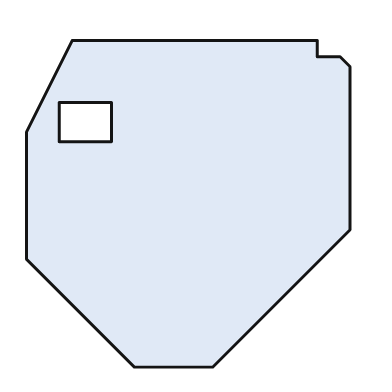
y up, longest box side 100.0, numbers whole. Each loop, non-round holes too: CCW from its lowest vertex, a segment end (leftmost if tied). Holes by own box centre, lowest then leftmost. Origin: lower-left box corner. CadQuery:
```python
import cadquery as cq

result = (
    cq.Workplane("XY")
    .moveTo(33.0, 0.0)
    .lineTo(57.0, 0.0)
    .lineTo(99.0, 42.0)
    .lineTo(99.0, 92.0)
    .lineTo(96.0, 95.0)
    .lineTo(89.0, 95.0)
    .lineTo(89.0, 100.0)
    .lineTo(14.0, 100.0)
    .lineTo(0.0, 72.0)
    .lineTo(0.0, 33.0)
    .close()
    .moveTo(10.0, 69.0)
    .lineTo(26.0, 69.0)
    .lineTo(26.0, 81.0)
    .lineTo(10.0, 81.0)
    .close()
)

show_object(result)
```